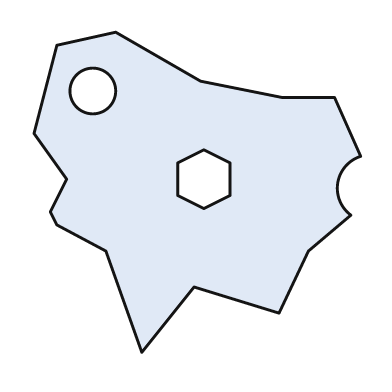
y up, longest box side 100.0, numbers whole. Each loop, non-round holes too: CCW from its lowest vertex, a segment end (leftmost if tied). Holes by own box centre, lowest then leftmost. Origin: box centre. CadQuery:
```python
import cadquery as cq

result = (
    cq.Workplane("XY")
    .moveTo(-17.0, -49.0)
    .lineTo(-1.0, -29.0)
    .lineTo(25.0, -37.0)
    .lineTo(34.0, -18.0)
    .lineTo(47.0, -7.0)
    .threePointArc((43.0, 3.0), (50.0, 11.0))
    .lineTo(42.0, 29.0)
    .lineTo(26.0, 29.0)
    .lineTo(1.0, 34.0)
    .lineTo(-25.0, 49.0)
    .lineTo(-43.0, 45.0)
    .lineTo(-50.0, 18.0)
    .lineTo(-40.0, 4.0)
    .lineTo(-45.0, -6.0)
    .lineTo(-43.0, -10.0)
    .lineTo(-28.0, -18.0)
    .close()
    .moveTo(2.0, -5.0)
    .lineTo(10.0, -1.0)
    .lineTo(10.0, 9.0)
    .lineTo(2.0, 13.0)
    .lineTo(-6.0, 9.0)
    .lineTo(-6.0, -1.0)
    .close()
    .moveTo(-32.0, 31.0)
    .circle(7.0)
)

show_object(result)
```